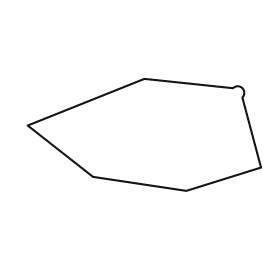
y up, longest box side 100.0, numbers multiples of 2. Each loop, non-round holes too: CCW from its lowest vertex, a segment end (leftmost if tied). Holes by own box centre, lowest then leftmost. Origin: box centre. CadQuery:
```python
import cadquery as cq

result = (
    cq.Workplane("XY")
    .moveTo(18.0, -24.0)
    .lineTo(50.0, -14.0)
    .lineTo(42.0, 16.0)
    .threePointArc((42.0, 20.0), (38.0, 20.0))
    .lineTo(0.0, 24.0)
    .lineTo(-50.0, 4.0)
    .lineTo(-22.0, -18.0)
    .close()
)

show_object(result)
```